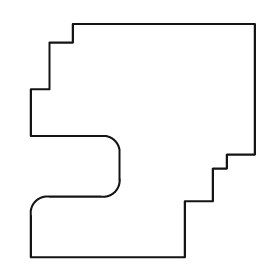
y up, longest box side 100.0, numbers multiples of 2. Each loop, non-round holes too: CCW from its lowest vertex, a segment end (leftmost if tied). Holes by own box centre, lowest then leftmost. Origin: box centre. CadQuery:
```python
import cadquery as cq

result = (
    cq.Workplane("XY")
    .moveTo(-48.0, -50.0)
    .lineTo(18.0, -50.0)
    .lineTo(18.0, -26.0)
    .lineTo(30.0, -26.0)
    .lineTo(30.0, -12.0)
    .lineTo(36.0, -12.0)
    .lineTo(36.0, -6.0)
    .lineTo(48.0, -6.0)
    .lineTo(48.0, 50.0)
    .lineTo(-30.0, 50.0)
    .lineTo(-30.0, 42.0)
    .lineTo(-40.0, 42.0)
    .lineTo(-40.0, 22.0)
    .lineTo(-48.0, 22.0)
    .lineTo(-48.0, 2.0)
    .lineTo(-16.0, 2.0)
    .threePointArc((-12.0, 0.0), (-10.0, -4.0))
    .lineTo(-10.0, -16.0)
    .threePointArc((-12.0, -22.0), (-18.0, -24.0))
    .lineTo(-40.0, -24.0)
    .threePointArc((-46.0, -26.0), (-48.0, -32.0))
    .close()
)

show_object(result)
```